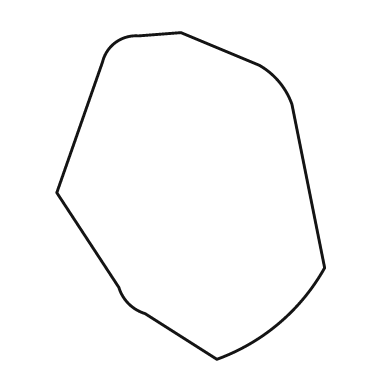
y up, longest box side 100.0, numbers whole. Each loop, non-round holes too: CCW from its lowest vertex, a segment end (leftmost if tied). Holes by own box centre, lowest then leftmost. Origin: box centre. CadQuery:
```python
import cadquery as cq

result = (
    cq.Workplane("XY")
    .moveTo(8.0, -50.0)
    .threePointArc((27.0, -39.0), (41.0, -22.0))
    .lineTo(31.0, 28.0)
    .threePointArc((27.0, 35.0), (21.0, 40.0))
    .lineTo(-3.0, 50.0)
    .lineTo(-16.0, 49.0)
    .threePointArc((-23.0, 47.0), (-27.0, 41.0))
    .lineTo(-41.0, 1.0)
    .lineTo(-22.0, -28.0)
    .threePointArc((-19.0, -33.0), (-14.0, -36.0))
    .close()
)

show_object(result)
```